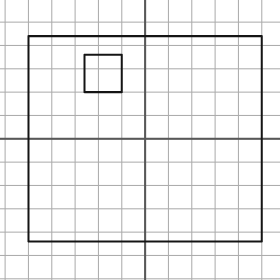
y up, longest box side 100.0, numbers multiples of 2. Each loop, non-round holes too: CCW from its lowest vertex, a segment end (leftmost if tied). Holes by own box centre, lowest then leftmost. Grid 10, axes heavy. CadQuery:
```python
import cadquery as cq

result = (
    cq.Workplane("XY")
    .moveTo(-50.0, -44.0)
    .lineTo(50.0, -44.0)
    .lineTo(50.0, 44.0)
    .lineTo(-50.0, 44.0)
    .close()
    .moveTo(-26.0, 20.0)
    .lineTo(-10.0, 20.0)
    .lineTo(-10.0, 36.0)
    .lineTo(-26.0, 36.0)
    .close()
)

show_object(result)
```